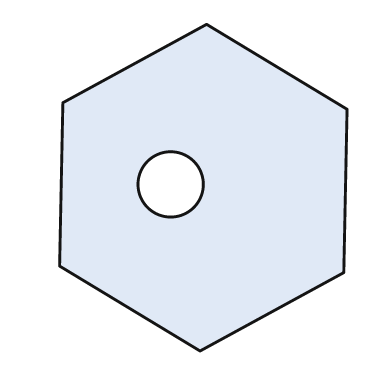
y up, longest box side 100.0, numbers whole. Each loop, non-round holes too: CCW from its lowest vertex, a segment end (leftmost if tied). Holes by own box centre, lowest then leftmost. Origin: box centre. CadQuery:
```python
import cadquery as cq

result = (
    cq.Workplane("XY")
    .moveTo(-1.0, -50.0)
    .lineTo(43.0, -26.0)
    .lineTo(44.0, 24.0)
    .lineTo(1.0, 50.0)
    .lineTo(-43.0, 26.0)
    .lineTo(-44.0, -24.0)
    .close()
    .moveTo(-10.0, 1.0)
    .circle(10.0)
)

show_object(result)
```